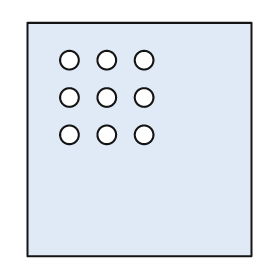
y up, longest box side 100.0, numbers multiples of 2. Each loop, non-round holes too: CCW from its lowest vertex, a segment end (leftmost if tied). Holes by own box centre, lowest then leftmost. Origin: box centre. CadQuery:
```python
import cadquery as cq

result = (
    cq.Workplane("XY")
    .moveTo(-48.0, -50.0)
    .lineTo(48.0, -50.0)
    .lineTo(48.0, 50.0)
    .lineTo(-48.0, 50.0)
    .close()
    .moveTo(-30.0, 2.0)
    .circle(4.0)
    .moveTo(-14.0, 2.0)
    .circle(4.0)
    .moveTo(2.0, 2.0)
    .circle(4.0)
    .moveTo(-30.0, 18.0)
    .circle(4.0)
    .moveTo(-14.0, 18.0)
    .circle(4.0)
    .moveTo(2.0, 18.0)
    .circle(4.0)
    .moveTo(-30.0, 34.0)
    .circle(4.0)
    .moveTo(-14.0, 34.0)
    .circle(4.0)
    .moveTo(2.0, 34.0)
    .circle(4.0)
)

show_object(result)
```